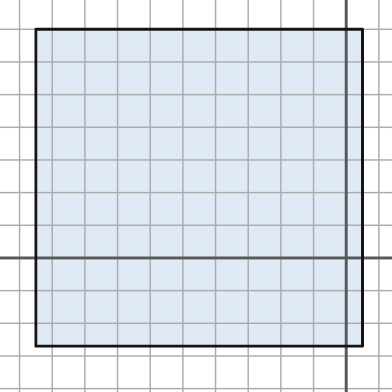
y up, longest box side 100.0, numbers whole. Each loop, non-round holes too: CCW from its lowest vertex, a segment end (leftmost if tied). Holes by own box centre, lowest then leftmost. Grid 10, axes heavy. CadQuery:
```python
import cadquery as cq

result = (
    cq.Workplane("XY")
    .moveTo(-95.0, -27.0)
    .lineTo(5.0, -27.0)
    .lineTo(5.0, 70.0)
    .lineTo(-95.0, 70.0)
    .close()
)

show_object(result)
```